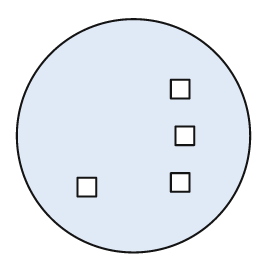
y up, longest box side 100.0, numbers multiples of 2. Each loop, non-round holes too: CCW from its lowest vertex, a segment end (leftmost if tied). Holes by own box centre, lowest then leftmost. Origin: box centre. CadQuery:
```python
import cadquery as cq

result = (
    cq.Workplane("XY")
    .moveTo(0.0, 0.0)
    .circle(50.0)
    .moveTo(-24.0, -26.0)
    .lineTo(-16.0, -26.0)
    .lineTo(-16.0, -18.0)
    .lineTo(-24.0, -18.0)
    .close()
    .moveTo(16.0, -24.0)
    .lineTo(24.0, -24.0)
    .lineTo(24.0, -16.0)
    .lineTo(16.0, -16.0)
    .close()
    .moveTo(18.0, -4.0)
    .lineTo(26.0, -4.0)
    .lineTo(26.0, 4.0)
    .lineTo(18.0, 4.0)
    .close()
    .moveTo(16.0, 16.0)
    .lineTo(24.0, 16.0)
    .lineTo(24.0, 24.0)
    .lineTo(16.0, 24.0)
    .close()
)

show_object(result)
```